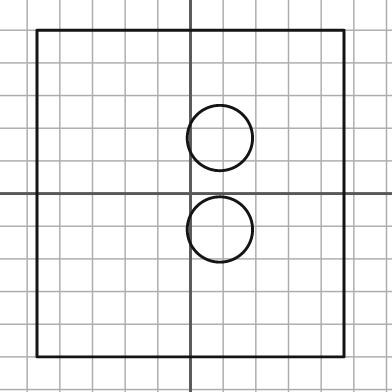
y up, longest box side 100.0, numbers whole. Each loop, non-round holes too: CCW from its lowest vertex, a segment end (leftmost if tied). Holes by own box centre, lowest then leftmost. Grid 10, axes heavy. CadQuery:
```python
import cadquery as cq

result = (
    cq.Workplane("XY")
    .moveTo(-47.0, -50.0)
    .lineTo(47.0, -50.0)
    .lineTo(47.0, 50.0)
    .lineTo(-47.0, 50.0)
    .close()
    .moveTo(9.0, -11.0)
    .circle(10.0)
    .moveTo(9.0, 17.0)
    .circle(10.0)
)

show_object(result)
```